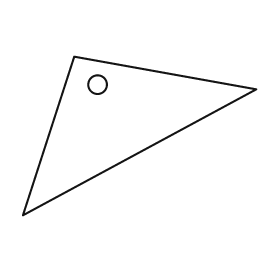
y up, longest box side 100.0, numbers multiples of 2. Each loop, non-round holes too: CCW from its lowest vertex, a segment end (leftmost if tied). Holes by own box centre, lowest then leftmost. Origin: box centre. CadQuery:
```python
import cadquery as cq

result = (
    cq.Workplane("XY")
    .moveTo(-50.0, -34.0)
    .lineTo(50.0, 20.0)
    .lineTo(-28.0, 34.0)
    .close()
    .moveTo(-18.0, 22.0)
    .circle(4.0)
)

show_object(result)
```